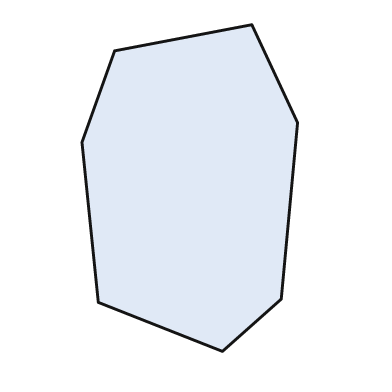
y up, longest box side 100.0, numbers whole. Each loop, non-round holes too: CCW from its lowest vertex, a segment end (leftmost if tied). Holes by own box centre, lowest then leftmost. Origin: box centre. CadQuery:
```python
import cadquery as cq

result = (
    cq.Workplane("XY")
    .moveTo(10.0, -50.0)
    .lineTo(28.0, -34.0)
    .lineTo(33.0, 20.0)
    .lineTo(19.0, 50.0)
    .lineTo(-23.0, 42.0)
    .lineTo(-33.0, 14.0)
    .lineTo(-28.0, -35.0)
    .close()
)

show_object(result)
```